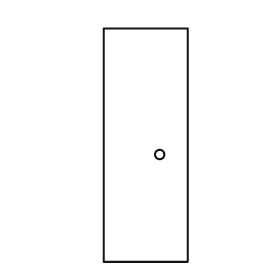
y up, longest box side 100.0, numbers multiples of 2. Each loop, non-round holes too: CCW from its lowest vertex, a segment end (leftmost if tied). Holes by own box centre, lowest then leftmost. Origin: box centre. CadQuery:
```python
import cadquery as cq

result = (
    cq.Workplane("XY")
    .moveTo(-18.0, -50.0)
    .lineTo(18.0, -50.0)
    .lineTo(18.0, 50.0)
    .lineTo(-18.0, 50.0)
    .close()
    .moveTo(6.0, -4.0)
    .circle(2.0)
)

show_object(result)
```